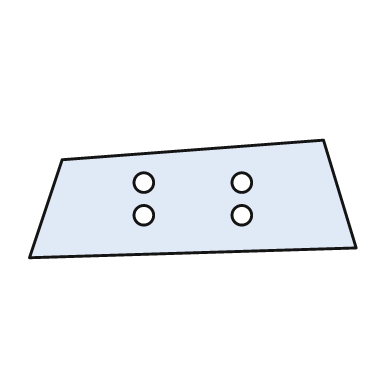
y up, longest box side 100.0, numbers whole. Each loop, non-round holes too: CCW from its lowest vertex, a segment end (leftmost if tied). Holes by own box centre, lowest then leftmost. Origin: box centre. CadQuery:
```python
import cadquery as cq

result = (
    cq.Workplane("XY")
    .moveTo(-50.0, -18.0)
    .lineTo(50.0, -15.0)
    .lineTo(40.0, 18.0)
    .lineTo(-40.0, 12.0)
    .close()
    .moveTo(-15.0, -5.0)
    .circle(3.0)
    .moveTo(15.0, -5.0)
    .circle(3.0)
    .moveTo(-15.0, 5.0)
    .circle(3.0)
    .moveTo(15.0, 5.0)
    .circle(3.0)
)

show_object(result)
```